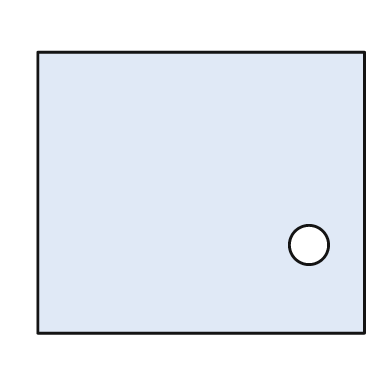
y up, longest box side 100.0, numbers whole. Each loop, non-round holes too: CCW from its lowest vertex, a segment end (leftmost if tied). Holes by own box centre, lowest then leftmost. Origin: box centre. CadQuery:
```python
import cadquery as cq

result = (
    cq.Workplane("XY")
    .moveTo(-50.0, -43.0)
    .lineTo(50.0, -43.0)
    .lineTo(50.0, 43.0)
    .lineTo(-50.0, 43.0)
    .close()
    .moveTo(33.0, -16.0)
    .circle(6.0)
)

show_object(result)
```